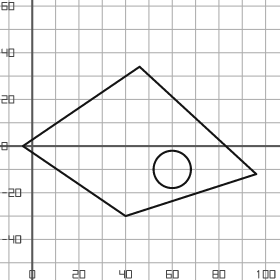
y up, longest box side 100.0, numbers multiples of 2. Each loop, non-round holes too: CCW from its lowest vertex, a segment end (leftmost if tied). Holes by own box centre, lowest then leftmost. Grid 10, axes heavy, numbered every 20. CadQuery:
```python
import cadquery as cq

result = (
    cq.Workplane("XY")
    .moveTo(40.0, -30.0)
    .lineTo(96.0, -12.0)
    .lineTo(46.0, 34.0)
    .lineTo(-4.0, 0.0)
    .close()
    .moveTo(60.0, -10.0)
    .circle(8.0)
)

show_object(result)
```